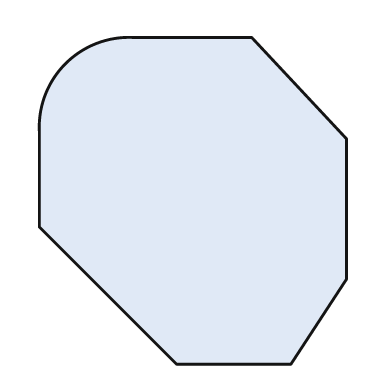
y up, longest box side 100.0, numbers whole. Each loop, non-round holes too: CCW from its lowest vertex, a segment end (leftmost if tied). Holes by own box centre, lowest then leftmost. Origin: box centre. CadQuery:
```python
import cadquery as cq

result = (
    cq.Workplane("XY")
    .moveTo(-5.0, -50.0)
    .lineTo(30.0, -50.0)
    .lineTo(47.0, -24.0)
    .lineTo(47.0, 19.0)
    .lineTo(18.0, 50.0)
    .lineTo(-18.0, 50.0)
    .threePointArc((-39.0, 42.0), (-47.0, 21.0))
    .lineTo(-47.0, -8.0)
    .close()
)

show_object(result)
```